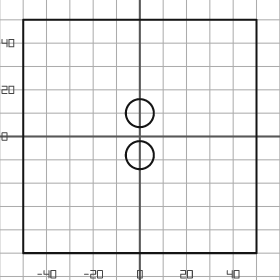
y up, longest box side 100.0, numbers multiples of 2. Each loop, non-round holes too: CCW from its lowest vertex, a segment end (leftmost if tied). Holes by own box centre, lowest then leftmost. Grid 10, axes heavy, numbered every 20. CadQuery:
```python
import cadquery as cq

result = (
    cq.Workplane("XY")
    .moveTo(-50.0, -50.0)
    .lineTo(50.0, -50.0)
    .lineTo(50.0, 50.0)
    .lineTo(-50.0, 50.0)
    .close()
    .moveTo(0.0, -8.0)
    .circle(6.0)
    .moveTo(0.0, 10.0)
    .circle(6.0)
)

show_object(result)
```